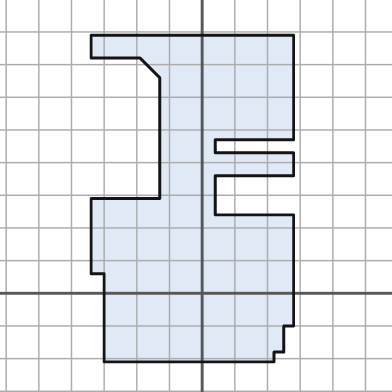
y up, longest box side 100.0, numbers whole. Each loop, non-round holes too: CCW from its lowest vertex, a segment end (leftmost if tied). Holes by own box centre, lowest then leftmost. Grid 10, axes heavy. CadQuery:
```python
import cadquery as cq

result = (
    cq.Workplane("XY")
    .moveTo(-30.0, -21.0)
    .lineTo(22.0, -21.0)
    .lineTo(22.0, -18.0)
    .lineTo(25.0, -18.0)
    .lineTo(25.0, -10.0)
    .lineTo(28.0, -10.0)
    .lineTo(28.0, 24.0)
    .lineTo(4.0, 24.0)
    .lineTo(4.0, 36.0)
    .lineTo(28.0, 36.0)
    .lineTo(28.0, 43.0)
    .lineTo(4.0, 43.0)
    .lineTo(4.0, 47.0)
    .lineTo(28.0, 47.0)
    .lineTo(28.0, 79.0)
    .lineTo(-34.0, 79.0)
    .lineTo(-34.0, 72.0)
    .lineTo(-19.0, 72.0)
    .lineTo(-13.0, 66.0)
    .lineTo(-13.0, 29.0)
    .lineTo(-34.0, 29.0)
    .lineTo(-34.0, 6.0)
    .lineTo(-30.0, 6.0)
    .close()
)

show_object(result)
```